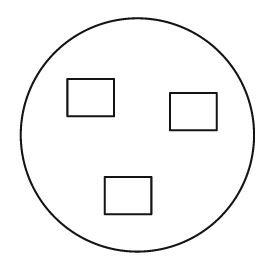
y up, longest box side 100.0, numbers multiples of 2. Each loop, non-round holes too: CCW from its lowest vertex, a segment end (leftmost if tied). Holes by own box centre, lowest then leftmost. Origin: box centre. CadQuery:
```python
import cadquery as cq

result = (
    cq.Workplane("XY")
    .moveTo(0.0, 0.0)
    .circle(50.0)
    .moveTo(-14.0, -34.0)
    .lineTo(6.0, -34.0)
    .lineTo(6.0, -18.0)
    .lineTo(-14.0, -18.0)
    .close()
    .moveTo(14.0, 2.0)
    .lineTo(34.0, 2.0)
    .lineTo(34.0, 18.0)
    .lineTo(14.0, 18.0)
    .close()
    .moveTo(-30.0, 8.0)
    .lineTo(-10.0, 8.0)
    .lineTo(-10.0, 24.0)
    .lineTo(-30.0, 24.0)
    .close()
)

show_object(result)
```